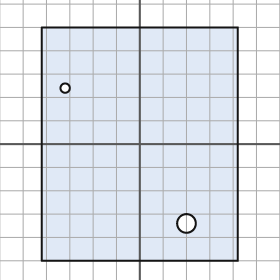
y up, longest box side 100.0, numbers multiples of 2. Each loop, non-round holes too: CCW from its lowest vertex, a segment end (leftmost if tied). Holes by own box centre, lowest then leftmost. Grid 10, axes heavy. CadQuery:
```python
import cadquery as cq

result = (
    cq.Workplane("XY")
    .moveTo(-42.0, -50.0)
    .lineTo(42.0, -50.0)
    .lineTo(42.0, 50.0)
    .lineTo(-42.0, 50.0)
    .close()
    .moveTo(20.0, -34.0)
    .circle(4.0)
    .moveTo(-32.0, 24.0)
    .circle(2.0)
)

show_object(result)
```